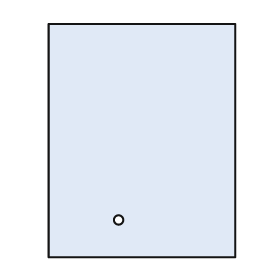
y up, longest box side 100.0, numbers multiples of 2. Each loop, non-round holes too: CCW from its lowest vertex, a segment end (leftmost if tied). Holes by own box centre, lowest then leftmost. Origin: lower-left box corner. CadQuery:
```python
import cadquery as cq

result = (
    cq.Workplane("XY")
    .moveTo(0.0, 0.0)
    .lineTo(80.0, 0.0)
    .lineTo(80.0, 100.0)
    .lineTo(0.0, 100.0)
    .close()
    .moveTo(30.0, 16.0)
    .circle(2.0)
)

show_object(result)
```